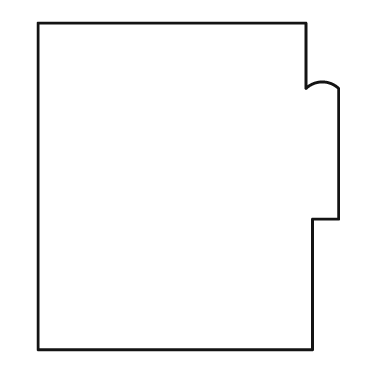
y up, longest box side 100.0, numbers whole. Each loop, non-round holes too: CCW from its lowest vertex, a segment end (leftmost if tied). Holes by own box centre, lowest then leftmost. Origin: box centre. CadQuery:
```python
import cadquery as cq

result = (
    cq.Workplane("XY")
    .moveTo(-46.0, -50.0)
    .lineTo(38.0, -50.0)
    .lineTo(38.0, -10.0)
    .lineTo(46.0, -10.0)
    .lineTo(46.0, 30.0)
    .threePointArc((41.0, 32.0), (36.0, 30.0))
    .lineTo(36.0, 50.0)
    .lineTo(-46.0, 50.0)
    .close()
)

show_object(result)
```